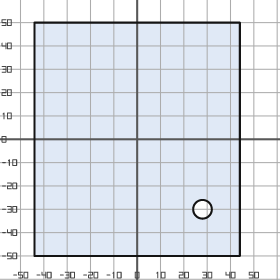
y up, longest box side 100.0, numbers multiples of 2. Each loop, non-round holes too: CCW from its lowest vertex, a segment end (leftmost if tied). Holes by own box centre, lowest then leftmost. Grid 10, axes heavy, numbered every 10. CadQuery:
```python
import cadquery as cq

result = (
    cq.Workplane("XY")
    .moveTo(-44.0, -50.0)
    .lineTo(44.0, -50.0)
    .lineTo(44.0, 50.0)
    .lineTo(-44.0, 50.0)
    .close()
    .moveTo(28.0, -30.0)
    .circle(4.0)
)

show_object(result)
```